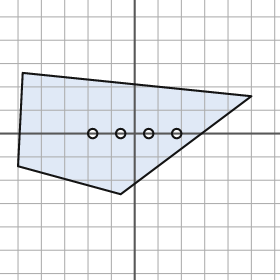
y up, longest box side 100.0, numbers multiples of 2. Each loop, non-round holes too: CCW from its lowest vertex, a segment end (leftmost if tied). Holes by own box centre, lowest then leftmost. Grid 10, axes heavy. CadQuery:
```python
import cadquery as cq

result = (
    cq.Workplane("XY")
    .moveTo(-6.0, -26.0)
    .lineTo(50.0, 16.0)
    .lineTo(-48.0, 26.0)
    .lineTo(-50.0, -14.0)
    .close()
    .moveTo(-18.0, 0.0)
    .circle(2.0)
    .moveTo(-6.0, 0.0)
    .circle(2.0)
    .moveTo(6.0, 0.0)
    .circle(2.0)
    .moveTo(18.0, 0.0)
    .circle(2.0)
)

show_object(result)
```